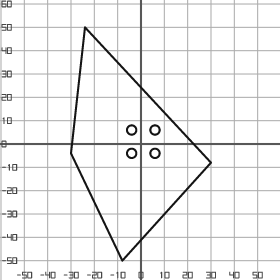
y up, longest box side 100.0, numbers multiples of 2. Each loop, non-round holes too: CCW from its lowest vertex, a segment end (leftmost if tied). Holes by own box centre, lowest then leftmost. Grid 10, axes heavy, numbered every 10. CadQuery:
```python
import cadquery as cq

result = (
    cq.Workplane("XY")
    .moveTo(-8.0, -50.0)
    .lineTo(30.0, -8.0)
    .lineTo(-24.0, 50.0)
    .lineTo(-30.0, -4.0)
    .close()
    .moveTo(-4.0, -4.0)
    .circle(2.0)
    .moveTo(6.0, -4.0)
    .circle(2.0)
    .moveTo(-4.0, 6.0)
    .circle(2.0)
    .moveTo(6.0, 6.0)
    .circle(2.0)
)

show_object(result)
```